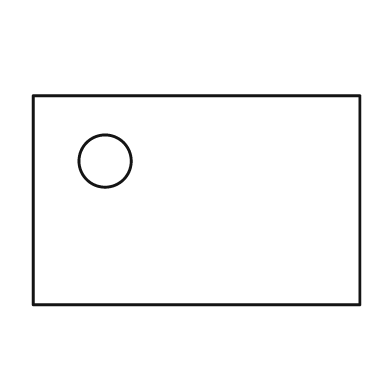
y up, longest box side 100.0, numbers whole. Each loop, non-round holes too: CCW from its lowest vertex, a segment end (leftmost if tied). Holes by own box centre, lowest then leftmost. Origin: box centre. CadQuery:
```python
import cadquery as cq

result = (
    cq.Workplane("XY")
    .moveTo(-50.0, -32.0)
    .lineTo(50.0, -32.0)
    .lineTo(50.0, 32.0)
    .lineTo(-50.0, 32.0)
    .close()
    .moveTo(-28.0, 12.0)
    .circle(8.0)
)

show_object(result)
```